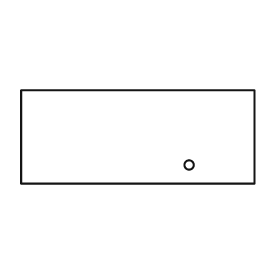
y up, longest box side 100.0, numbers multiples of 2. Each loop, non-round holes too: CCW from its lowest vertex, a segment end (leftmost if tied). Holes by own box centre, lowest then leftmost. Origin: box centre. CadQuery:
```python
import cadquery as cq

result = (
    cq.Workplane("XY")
    .moveTo(-50.0, -20.0)
    .lineTo(50.0, -20.0)
    .lineTo(50.0, 20.0)
    .lineTo(-50.0, 20.0)
    .close()
    .moveTo(22.0, -12.0)
    .circle(2.0)
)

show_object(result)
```